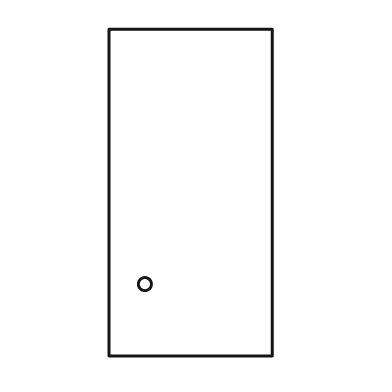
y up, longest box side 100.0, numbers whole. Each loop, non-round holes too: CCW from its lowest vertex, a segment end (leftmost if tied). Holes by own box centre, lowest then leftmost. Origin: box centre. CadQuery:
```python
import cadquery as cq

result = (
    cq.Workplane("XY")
    .moveTo(-25.0, -50.0)
    .lineTo(25.0, -50.0)
    .lineTo(25.0, 50.0)
    .lineTo(-25.0, 50.0)
    .close()
    .moveTo(-14.0, -28.0)
    .circle(2.0)
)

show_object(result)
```